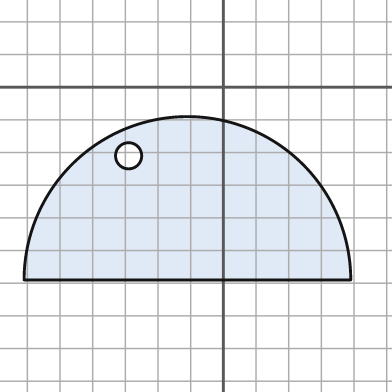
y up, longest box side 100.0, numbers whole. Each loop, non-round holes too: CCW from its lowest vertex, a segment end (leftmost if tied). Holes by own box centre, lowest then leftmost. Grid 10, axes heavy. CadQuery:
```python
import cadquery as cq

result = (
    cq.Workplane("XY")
    .moveTo(-61.0, -59.0)
    .lineTo(39.0, -59.0)
    .threePointArc((-11.0, -9.0), (-61.0, -59.0))
    .close()
    .moveTo(-29.0, -21.0)
    .circle(4.0)
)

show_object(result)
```